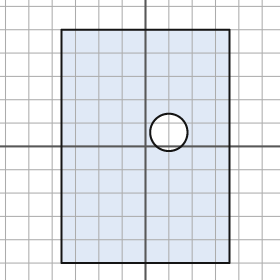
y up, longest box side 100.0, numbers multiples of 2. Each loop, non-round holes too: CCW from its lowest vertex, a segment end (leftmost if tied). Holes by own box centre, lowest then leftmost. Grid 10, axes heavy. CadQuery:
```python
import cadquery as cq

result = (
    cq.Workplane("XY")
    .moveTo(-36.0, -50.0)
    .lineTo(36.0, -50.0)
    .lineTo(36.0, 50.0)
    .lineTo(-36.0, 50.0)
    .close()
    .moveTo(10.0, 6.0)
    .circle(8.0)
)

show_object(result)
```